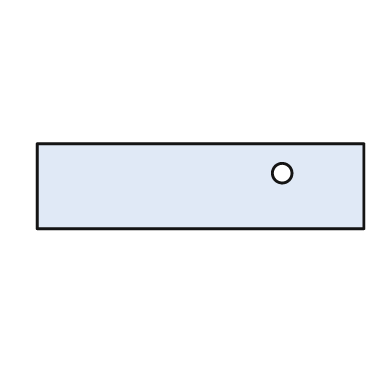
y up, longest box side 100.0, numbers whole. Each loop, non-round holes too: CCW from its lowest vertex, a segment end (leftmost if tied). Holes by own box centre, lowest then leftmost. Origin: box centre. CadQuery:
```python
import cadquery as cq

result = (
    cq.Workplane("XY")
    .moveTo(-50.0, -13.0)
    .lineTo(50.0, -13.0)
    .lineTo(50.0, 13.0)
    .lineTo(-50.0, 13.0)
    .close()
    .moveTo(25.0, 4.0)
    .circle(3.0)
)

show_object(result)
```